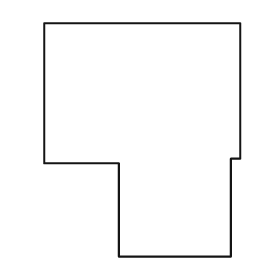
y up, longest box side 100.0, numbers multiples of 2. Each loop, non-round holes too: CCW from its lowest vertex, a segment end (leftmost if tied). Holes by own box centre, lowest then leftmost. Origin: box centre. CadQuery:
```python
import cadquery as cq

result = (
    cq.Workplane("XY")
    .moveTo(-10.0, -50.0)
    .lineTo(38.0, -50.0)
    .lineTo(38.0, -8.0)
    .lineTo(42.0, -8.0)
    .lineTo(42.0, 50.0)
    .lineTo(-42.0, 50.0)
    .lineTo(-42.0, -10.0)
    .lineTo(-10.0, -10.0)
    .close()
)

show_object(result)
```